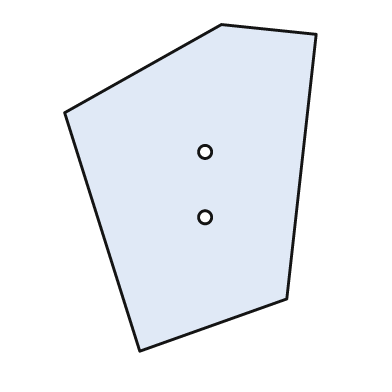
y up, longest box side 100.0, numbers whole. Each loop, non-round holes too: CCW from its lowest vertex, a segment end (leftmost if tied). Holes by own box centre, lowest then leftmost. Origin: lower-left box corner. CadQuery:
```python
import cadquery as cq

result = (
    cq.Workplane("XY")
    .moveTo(23.0, 0.0)
    .lineTo(68.0, 16.0)
    .lineTo(77.0, 97.0)
    .lineTo(48.0, 100.0)
    .lineTo(0.0, 73.0)
    .close()
    .moveTo(43.0, 41.0)
    .circle(2.0)
    .moveTo(43.0, 61.0)
    .circle(2.0)
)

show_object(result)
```